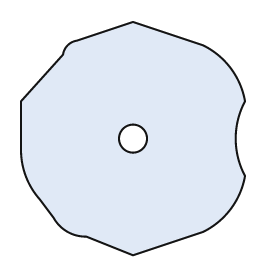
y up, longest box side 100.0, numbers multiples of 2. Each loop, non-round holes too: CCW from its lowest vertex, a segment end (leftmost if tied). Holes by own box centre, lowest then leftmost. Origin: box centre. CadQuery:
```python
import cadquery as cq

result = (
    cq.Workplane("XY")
    .moveTo(0.0, -50.0)
    .lineTo(30.0, -40.0)
    .threePointArc((42.0, -30.0), (48.0, -16.0))
    .threePointArc((44.0, 0.0), (48.0, 16.0))
    .threePointArc((42.0, 30.0), (30.0, 40.0))
    .lineTo(0.0, 50.0)
    .lineTo(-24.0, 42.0)
    .threePointArc((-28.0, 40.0), (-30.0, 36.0))
    .lineTo(-48.0, 16.0)
    .lineTo(-48.0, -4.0)
    .threePointArc((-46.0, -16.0), (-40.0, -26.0))
    .lineTo(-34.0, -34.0)
    .threePointArc((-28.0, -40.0), (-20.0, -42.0))
    .close()
    .moveTo(0.0, 0.0)
    .circle(6.0)
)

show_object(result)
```